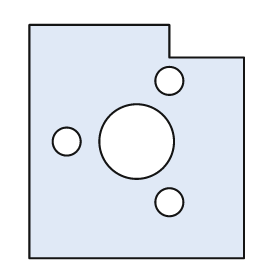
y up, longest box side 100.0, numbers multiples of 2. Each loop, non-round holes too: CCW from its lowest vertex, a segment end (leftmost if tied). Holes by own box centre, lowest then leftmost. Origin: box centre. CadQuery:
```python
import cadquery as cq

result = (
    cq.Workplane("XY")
    .moveTo(-46.0, -50.0)
    .lineTo(46.0, -50.0)
    .lineTo(46.0, 36.0)
    .lineTo(14.0, 36.0)
    .lineTo(14.0, 50.0)
    .lineTo(-46.0, 50.0)
    .close()
    .moveTo(14.0, -26.0)
    .circle(6.0)
    .moveTo(-30.0, 0.0)
    .circle(6.0)
    .moveTo(0.0, 0.0)
    .circle(16.0)
    .moveTo(14.0, 26.0)
    .circle(6.0)
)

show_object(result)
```